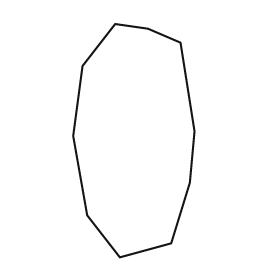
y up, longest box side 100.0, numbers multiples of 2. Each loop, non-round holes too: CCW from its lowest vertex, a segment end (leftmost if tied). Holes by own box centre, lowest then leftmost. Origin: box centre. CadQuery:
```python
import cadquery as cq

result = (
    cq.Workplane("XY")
    .moveTo(-6.0, -50.0)
    .lineTo(16.0, -44.0)
    .lineTo(24.0, -18.0)
    .lineTo(26.0, 4.0)
    .lineTo(20.0, 42.0)
    .lineTo(6.0, 48.0)
    .lineTo(-8.0, 50.0)
    .lineTo(-22.0, 32.0)
    .lineTo(-26.0, 2.0)
    .lineTo(-20.0, -32.0)
    .close()
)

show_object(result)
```